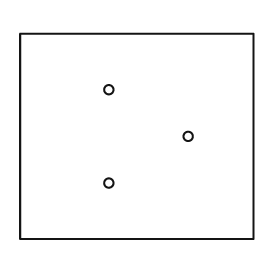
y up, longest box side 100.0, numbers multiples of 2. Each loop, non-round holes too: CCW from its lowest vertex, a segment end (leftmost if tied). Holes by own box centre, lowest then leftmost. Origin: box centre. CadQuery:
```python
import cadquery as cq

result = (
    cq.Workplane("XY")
    .moveTo(-50.0, -44.0)
    .lineTo(50.0, -44.0)
    .lineTo(50.0, 44.0)
    .lineTo(-50.0, 44.0)
    .close()
    .moveTo(-12.0, -20.0)
    .circle(2.0)
    .moveTo(22.0, 0.0)
    .circle(2.0)
    .moveTo(-12.0, 20.0)
    .circle(2.0)
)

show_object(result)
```